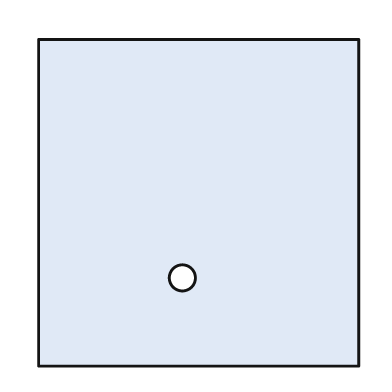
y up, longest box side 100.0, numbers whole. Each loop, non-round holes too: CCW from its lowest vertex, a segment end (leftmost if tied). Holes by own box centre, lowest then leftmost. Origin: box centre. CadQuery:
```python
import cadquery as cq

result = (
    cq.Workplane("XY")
    .moveTo(-49.0, -50.0)
    .lineTo(49.0, -50.0)
    .lineTo(49.0, 50.0)
    .lineTo(-49.0, 50.0)
    .close()
    .moveTo(-5.0, -23.0)
    .circle(4.0)
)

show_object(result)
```